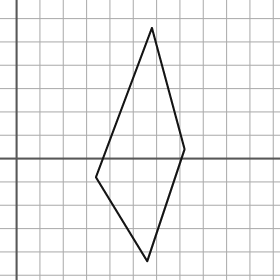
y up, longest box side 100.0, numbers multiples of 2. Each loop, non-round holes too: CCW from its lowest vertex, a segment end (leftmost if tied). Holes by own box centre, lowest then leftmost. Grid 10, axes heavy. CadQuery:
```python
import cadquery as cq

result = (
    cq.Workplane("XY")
    .moveTo(56.0, -44.0)
    .lineTo(72.0, 4.0)
    .lineTo(58.0, 56.0)
    .lineTo(34.0, -8.0)
    .close()
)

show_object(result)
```